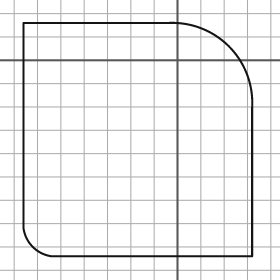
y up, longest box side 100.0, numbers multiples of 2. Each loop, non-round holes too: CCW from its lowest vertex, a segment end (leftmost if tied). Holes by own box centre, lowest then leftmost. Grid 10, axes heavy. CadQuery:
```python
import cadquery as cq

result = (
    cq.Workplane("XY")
    .moveTo(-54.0, -84.0)
    .lineTo(32.0, -84.0)
    .lineTo(32.0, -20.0)
    .threePointArc((22.0, 6.0), (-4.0, 16.0))
    .lineTo(-66.0, 16.0)
    .lineTo(-66.0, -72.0)
    .threePointArc((-62.0, -80.0), (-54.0, -84.0))
    .close()
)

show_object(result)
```